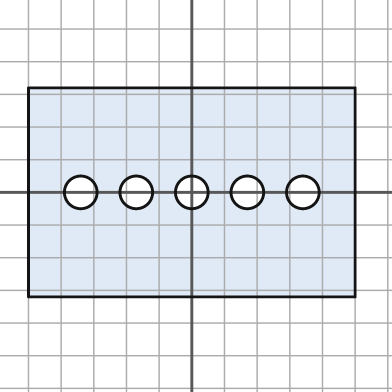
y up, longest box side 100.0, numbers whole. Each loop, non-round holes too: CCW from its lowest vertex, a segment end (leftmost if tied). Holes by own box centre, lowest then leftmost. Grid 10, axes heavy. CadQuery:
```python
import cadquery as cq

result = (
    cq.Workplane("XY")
    .moveTo(-50.0, -32.0)
    .lineTo(50.0, -32.0)
    .lineTo(50.0, 32.0)
    .lineTo(-50.0, 32.0)
    .close()
    .moveTo(-34.0, 0.0)
    .circle(5.0)
    .moveTo(-17.0, 0.0)
    .circle(5.0)
    .moveTo(0.0, 0.0)
    .circle(5.0)
    .moveTo(17.0, 0.0)
    .circle(5.0)
    .moveTo(34.0, 0.0)
    .circle(5.0)
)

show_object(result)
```